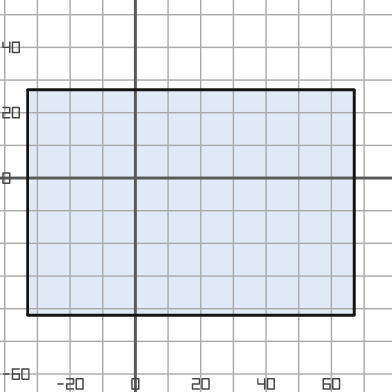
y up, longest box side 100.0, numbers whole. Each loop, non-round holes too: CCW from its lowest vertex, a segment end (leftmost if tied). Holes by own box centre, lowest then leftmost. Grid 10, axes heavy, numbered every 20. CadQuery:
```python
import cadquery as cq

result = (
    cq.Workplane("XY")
    .moveTo(-33.0, -42.0)
    .lineTo(67.0, -42.0)
    .lineTo(67.0, 27.0)
    .lineTo(-33.0, 27.0)
    .close()
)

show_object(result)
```